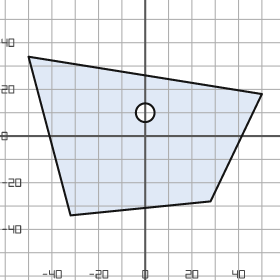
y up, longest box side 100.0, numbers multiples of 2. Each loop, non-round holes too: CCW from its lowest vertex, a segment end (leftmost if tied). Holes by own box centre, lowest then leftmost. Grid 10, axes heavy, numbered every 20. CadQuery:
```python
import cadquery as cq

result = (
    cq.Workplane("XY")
    .moveTo(-32.0, -34.0)
    .lineTo(28.0, -28.0)
    .lineTo(50.0, 18.0)
    .lineTo(-50.0, 34.0)
    .close()
    .moveTo(0.0, 10.0)
    .circle(4.0)
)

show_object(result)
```